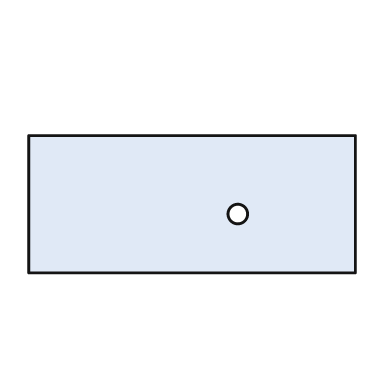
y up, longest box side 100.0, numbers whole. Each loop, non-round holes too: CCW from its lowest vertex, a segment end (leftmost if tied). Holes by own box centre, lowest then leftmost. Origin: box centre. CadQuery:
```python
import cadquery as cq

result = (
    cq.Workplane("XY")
    .moveTo(-50.0, -21.0)
    .lineTo(50.0, -21.0)
    .lineTo(50.0, 21.0)
    .lineTo(-50.0, 21.0)
    .close()
    .moveTo(14.0, -3.0)
    .circle(3.0)
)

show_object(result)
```